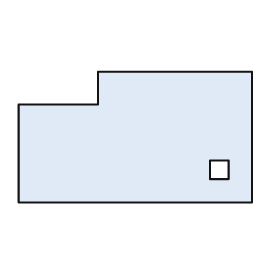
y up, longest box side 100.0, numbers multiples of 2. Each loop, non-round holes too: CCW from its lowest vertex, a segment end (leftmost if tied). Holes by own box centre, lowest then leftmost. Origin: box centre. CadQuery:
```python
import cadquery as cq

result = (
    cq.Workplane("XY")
    .moveTo(-50.0, -28.0)
    .lineTo(50.0, -28.0)
    .lineTo(50.0, 28.0)
    .lineTo(-16.0, 28.0)
    .lineTo(-16.0, 14.0)
    .lineTo(-50.0, 14.0)
    .close()
    .moveTo(32.0, -18.0)
    .lineTo(40.0, -18.0)
    .lineTo(40.0, -10.0)
    .lineTo(32.0, -10.0)
    .close()
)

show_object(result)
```